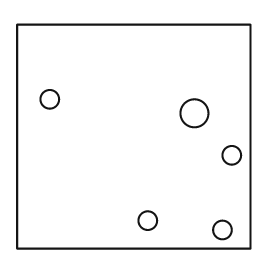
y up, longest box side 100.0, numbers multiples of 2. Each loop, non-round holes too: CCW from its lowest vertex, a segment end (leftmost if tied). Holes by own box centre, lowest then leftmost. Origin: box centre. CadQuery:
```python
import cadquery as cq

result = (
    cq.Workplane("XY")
    .moveTo(-50.0, -48.0)
    .lineTo(50.0, -48.0)
    .lineTo(50.0, 48.0)
    .lineTo(-50.0, 48.0)
    .close()
    .moveTo(38.0, -40.0)
    .circle(4.0)
    .moveTo(6.0, -36.0)
    .circle(4.0)
    .moveTo(42.0, -8.0)
    .circle(4.0)
    .moveTo(26.0, 10.0)
    .circle(6.0)
    .moveTo(-36.0, 16.0)
    .circle(4.0)
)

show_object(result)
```